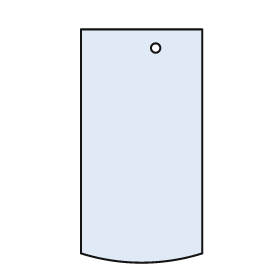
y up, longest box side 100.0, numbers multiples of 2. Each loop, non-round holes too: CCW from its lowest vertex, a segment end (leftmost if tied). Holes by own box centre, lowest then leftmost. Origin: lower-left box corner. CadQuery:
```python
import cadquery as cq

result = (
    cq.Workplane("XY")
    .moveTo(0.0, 4.0)
    .threePointArc((26.0, 0.0), (52.0, 4.0))
    .lineTo(52.0, 100.0)
    .lineTo(0.0, 100.0)
    .close()
    .moveTo(32.0, 92.0)
    .circle(2.0)
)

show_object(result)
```